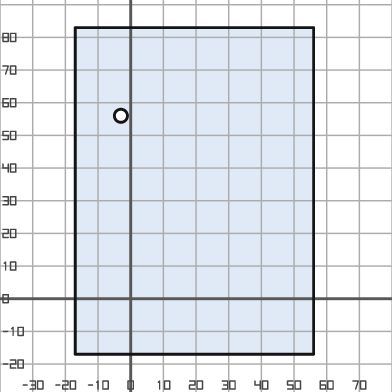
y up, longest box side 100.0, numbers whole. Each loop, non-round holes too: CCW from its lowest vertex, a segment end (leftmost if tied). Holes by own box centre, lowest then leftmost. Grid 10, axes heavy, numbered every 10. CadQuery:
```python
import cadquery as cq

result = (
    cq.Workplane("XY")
    .moveTo(-17.0, -17.0)
    .lineTo(56.0, -17.0)
    .lineTo(56.0, 83.0)
    .lineTo(-17.0, 83.0)
    .close()
    .moveTo(-3.0, 56.0)
    .circle(2.0)
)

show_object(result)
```